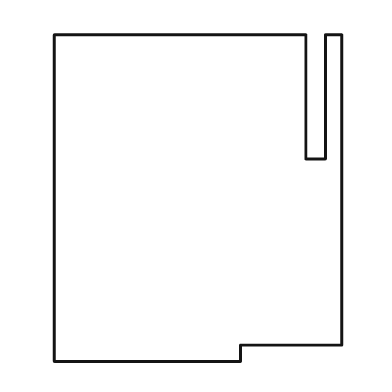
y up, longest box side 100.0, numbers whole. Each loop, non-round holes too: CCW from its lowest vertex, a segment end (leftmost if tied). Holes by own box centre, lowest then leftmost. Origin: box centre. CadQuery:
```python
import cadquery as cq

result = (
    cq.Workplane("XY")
    .moveTo(-44.0, -50.0)
    .lineTo(13.0, -50.0)
    .lineTo(13.0, -45.0)
    .lineTo(44.0, -45.0)
    .lineTo(44.0, 50.0)
    .lineTo(39.0, 50.0)
    .lineTo(39.0, 12.0)
    .lineTo(33.0, 12.0)
    .lineTo(33.0, 50.0)
    .lineTo(-44.0, 50.0)
    .close()
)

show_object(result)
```